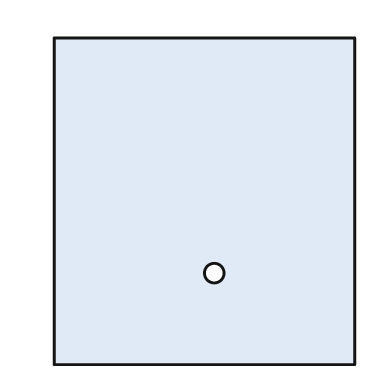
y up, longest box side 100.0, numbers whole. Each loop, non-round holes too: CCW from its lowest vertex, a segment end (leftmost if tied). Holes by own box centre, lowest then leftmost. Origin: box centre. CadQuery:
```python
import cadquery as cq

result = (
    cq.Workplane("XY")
    .moveTo(-46.0, -50.0)
    .lineTo(46.0, -50.0)
    .lineTo(46.0, 50.0)
    .lineTo(-46.0, 50.0)
    .close()
    .moveTo(3.0, -22.0)
    .circle(3.0)
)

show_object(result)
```